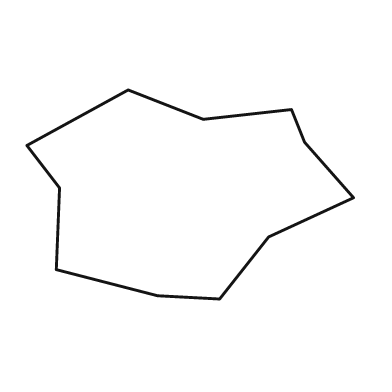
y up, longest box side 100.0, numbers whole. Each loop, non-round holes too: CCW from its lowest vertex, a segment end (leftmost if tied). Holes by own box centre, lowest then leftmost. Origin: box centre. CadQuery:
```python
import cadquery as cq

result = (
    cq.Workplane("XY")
    .moveTo(9.0, -32.0)
    .lineTo(24.0, -13.0)
    .lineTo(50.0, -1.0)
    .lineTo(35.0, 16.0)
    .lineTo(31.0, 26.0)
    .lineTo(4.0, 23.0)
    .lineTo(-19.0, 32.0)
    .lineTo(-50.0, 15.0)
    .lineTo(-40.0, 2.0)
    .lineTo(-41.0, -23.0)
    .lineTo(-10.0, -31.0)
    .close()
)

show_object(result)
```